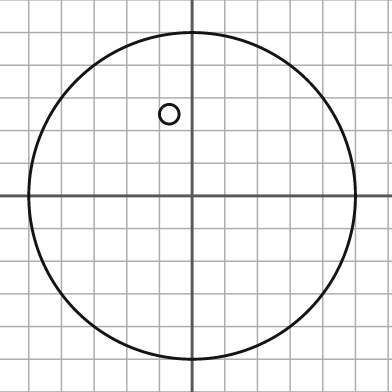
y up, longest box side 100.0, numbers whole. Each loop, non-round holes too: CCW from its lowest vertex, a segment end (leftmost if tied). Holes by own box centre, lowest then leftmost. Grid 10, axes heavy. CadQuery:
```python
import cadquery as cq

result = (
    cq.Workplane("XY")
    .moveTo(0.0, 0.0)
    .circle(50.0)
    .moveTo(-7.0, 25.0)
    .circle(3.0)
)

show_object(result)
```